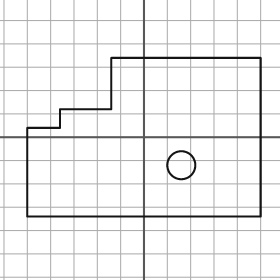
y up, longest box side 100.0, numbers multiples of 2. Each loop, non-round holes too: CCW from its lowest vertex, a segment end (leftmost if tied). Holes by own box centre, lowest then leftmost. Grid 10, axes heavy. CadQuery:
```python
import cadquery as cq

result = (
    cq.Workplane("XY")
    .moveTo(-50.0, -34.0)
    .lineTo(50.0, -34.0)
    .lineTo(50.0, 34.0)
    .lineTo(-14.0, 34.0)
    .lineTo(-14.0, 12.0)
    .lineTo(-36.0, 12.0)
    .lineTo(-36.0, 4.0)
    .lineTo(-50.0, 4.0)
    .close()
    .moveTo(16.0, -12.0)
    .circle(6.0)
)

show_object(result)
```